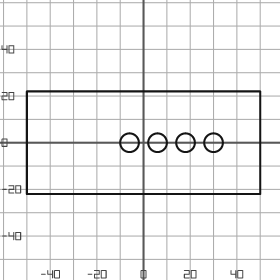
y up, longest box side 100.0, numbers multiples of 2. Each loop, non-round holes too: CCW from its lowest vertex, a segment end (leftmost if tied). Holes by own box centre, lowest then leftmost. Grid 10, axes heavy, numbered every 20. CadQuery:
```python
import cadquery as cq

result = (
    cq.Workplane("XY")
    .moveTo(-50.0, -22.0)
    .lineTo(50.0, -22.0)
    .lineTo(50.0, 22.0)
    .lineTo(-50.0, 22.0)
    .close()
    .moveTo(-6.0, 0.0)
    .circle(4.0)
    .moveTo(6.0, 0.0)
    .circle(4.0)
    .moveTo(18.0, 0.0)
    .circle(4.0)
    .moveTo(30.0, 0.0)
    .circle(4.0)
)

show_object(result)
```